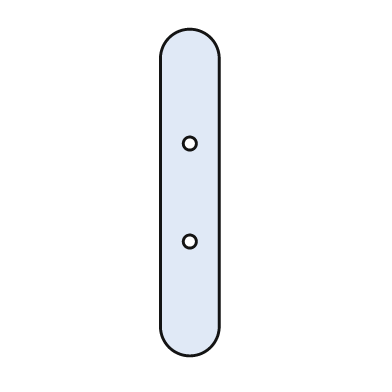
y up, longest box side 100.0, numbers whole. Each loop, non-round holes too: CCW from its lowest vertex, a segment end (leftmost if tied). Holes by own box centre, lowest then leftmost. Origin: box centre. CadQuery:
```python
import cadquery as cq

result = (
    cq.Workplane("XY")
    .moveTo(-9.0, -41.0)
    .threePointArc((0.0, -50.0), (9.0, -41.0))
    .lineTo(9.0, 41.0)
    .threePointArc((0.0, 50.0), (-9.0, 41.0))
    .close()
    .moveTo(0.0, -15.0)
    .circle(2.0)
    .moveTo(0.0, 15.0)
    .circle(2.0)
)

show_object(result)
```